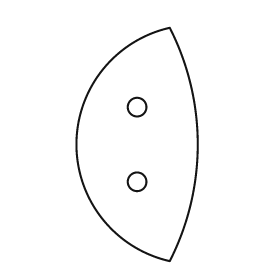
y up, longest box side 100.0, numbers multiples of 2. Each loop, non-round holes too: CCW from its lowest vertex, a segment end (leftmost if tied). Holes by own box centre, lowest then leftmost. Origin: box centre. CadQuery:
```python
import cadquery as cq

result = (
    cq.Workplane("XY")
    .moveTo(14.0, -50.0)
    .threePointArc((26.0, 0.0), (14.0, 50.0))
    .threePointArc((-26.0, 0.0), (14.0, -50.0))
    .close()
    .moveTo(0.0, -16.0)
    .circle(4.0)
    .moveTo(0.0, 16.0)
    .circle(4.0)
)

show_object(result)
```